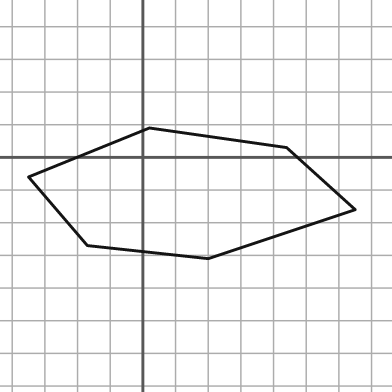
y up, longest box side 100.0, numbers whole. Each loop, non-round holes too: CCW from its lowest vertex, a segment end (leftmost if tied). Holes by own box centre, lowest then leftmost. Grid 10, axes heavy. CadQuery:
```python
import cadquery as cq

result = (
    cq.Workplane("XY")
    .moveTo(20.0, -31.0)
    .lineTo(65.0, -16.0)
    .lineTo(44.0, 3.0)
    .lineTo(2.0, 9.0)
    .lineTo(-35.0, -6.0)
    .lineTo(-17.0, -27.0)
    .close()
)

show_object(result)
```